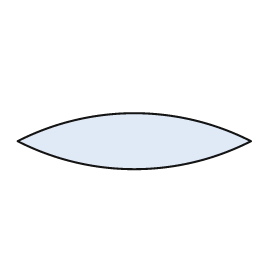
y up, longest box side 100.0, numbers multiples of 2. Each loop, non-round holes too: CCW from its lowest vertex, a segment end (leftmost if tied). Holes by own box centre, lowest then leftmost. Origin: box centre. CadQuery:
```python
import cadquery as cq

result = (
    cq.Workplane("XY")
    .moveTo(-50.0, 0.0)
    .threePointArc((0.0, -12.0), (50.0, 0.0))
    .threePointArc((0.0, 12.0), (-50.0, 0.0))
    .close()
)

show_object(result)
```